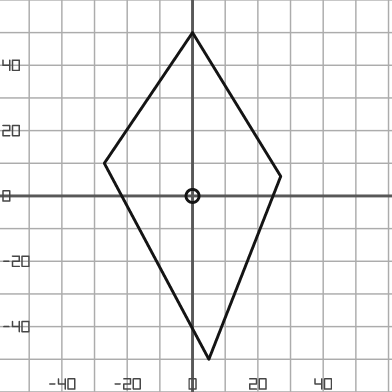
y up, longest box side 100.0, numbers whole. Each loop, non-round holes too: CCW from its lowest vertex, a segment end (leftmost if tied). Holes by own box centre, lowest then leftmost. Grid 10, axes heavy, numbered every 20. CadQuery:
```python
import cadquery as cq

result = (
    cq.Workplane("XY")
    .moveTo(5.0, -50.0)
    .lineTo(27.0, 6.0)
    .lineTo(0.0, 50.0)
    .lineTo(-27.0, 10.0)
    .close()
    .moveTo(0.0, 0.0)
    .circle(2.0)
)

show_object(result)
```